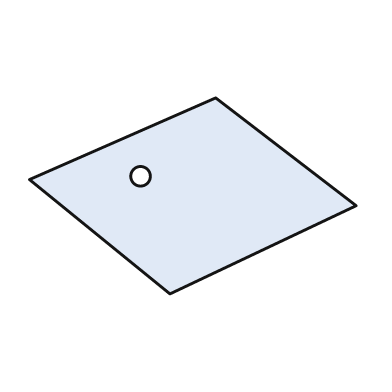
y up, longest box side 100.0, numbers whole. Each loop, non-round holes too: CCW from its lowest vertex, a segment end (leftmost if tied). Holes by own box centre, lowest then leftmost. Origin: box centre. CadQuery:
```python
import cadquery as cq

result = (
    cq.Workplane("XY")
    .moveTo(-7.0, -30.0)
    .lineTo(50.0, -3.0)
    .lineTo(7.0, 30.0)
    .lineTo(-50.0, 5.0)
    .close()
    .moveTo(-16.0, 6.0)
    .circle(3.0)
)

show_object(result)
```